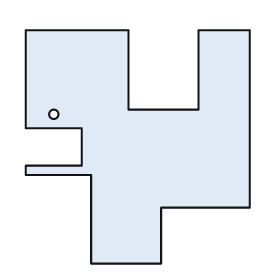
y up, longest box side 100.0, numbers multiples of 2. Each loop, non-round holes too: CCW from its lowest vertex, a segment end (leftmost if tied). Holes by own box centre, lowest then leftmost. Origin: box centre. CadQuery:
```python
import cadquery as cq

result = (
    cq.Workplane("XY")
    .moveTo(-20.0, -50.0)
    .lineTo(10.0, -50.0)
    .lineTo(10.0, -26.0)
    .lineTo(48.0, -26.0)
    .lineTo(48.0, 50.0)
    .lineTo(26.0, 50.0)
    .lineTo(26.0, 16.0)
    .lineTo(-4.0, 16.0)
    .lineTo(-4.0, 50.0)
    .lineTo(-48.0, 50.0)
    .lineTo(-48.0, 8.0)
    .lineTo(-24.0, 8.0)
    .lineTo(-24.0, -8.0)
    .lineTo(-48.0, -8.0)
    .lineTo(-48.0, -12.0)
    .lineTo(-20.0, -12.0)
    .close()
    .moveTo(-36.0, 14.0)
    .circle(2.0)
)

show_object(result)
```